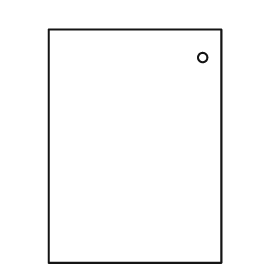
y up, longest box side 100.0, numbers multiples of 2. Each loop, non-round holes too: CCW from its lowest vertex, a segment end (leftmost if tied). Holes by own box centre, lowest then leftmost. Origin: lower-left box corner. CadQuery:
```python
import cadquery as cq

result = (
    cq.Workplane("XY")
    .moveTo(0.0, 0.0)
    .lineTo(74.0, 0.0)
    .lineTo(74.0, 100.0)
    .lineTo(0.0, 100.0)
    .close()
    .moveTo(66.0, 88.0)
    .circle(2.0)
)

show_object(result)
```